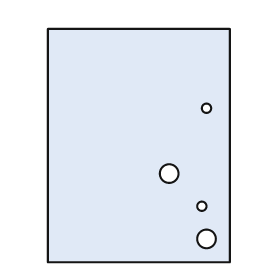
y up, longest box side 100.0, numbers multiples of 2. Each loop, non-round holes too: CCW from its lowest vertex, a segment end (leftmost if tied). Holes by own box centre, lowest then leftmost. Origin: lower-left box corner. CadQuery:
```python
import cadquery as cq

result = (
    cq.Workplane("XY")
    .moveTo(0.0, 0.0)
    .lineTo(78.0, 0.0)
    .lineTo(78.0, 100.0)
    .lineTo(0.0, 100.0)
    .close()
    .moveTo(68.0, 10.0)
    .circle(4.0)
    .moveTo(66.0, 24.0)
    .circle(2.0)
    .moveTo(52.0, 38.0)
    .circle(4.0)
    .moveTo(68.0, 66.0)
    .circle(2.0)
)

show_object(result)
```